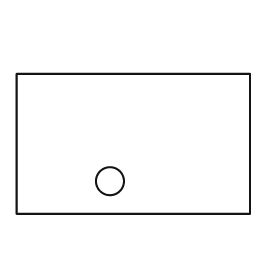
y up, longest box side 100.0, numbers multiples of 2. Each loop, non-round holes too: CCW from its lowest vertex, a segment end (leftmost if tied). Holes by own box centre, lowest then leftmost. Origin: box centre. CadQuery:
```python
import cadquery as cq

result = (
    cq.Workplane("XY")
    .moveTo(-50.0, -30.0)
    .lineTo(50.0, -30.0)
    .lineTo(50.0, 30.0)
    .lineTo(-50.0, 30.0)
    .close()
    .moveTo(-10.0, -16.0)
    .circle(6.0)
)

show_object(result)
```